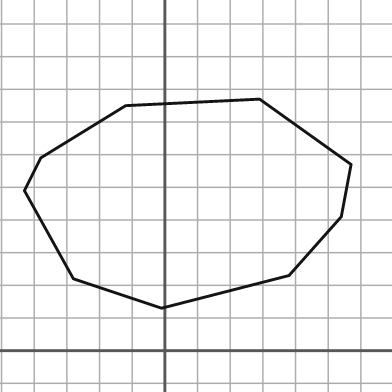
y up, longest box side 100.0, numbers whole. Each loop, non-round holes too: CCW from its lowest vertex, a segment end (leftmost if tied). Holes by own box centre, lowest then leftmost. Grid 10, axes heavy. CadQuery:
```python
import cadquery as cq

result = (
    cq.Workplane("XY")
    .moveTo(-1.0, 13.0)
    .lineTo(38.0, 23.0)
    .lineTo(54.0, 41.0)
    .lineTo(57.0, 57.0)
    .lineTo(29.0, 77.0)
    .lineTo(-12.0, 75.0)
    .lineTo(-38.0, 59.0)
    .lineTo(-43.0, 49.0)
    .lineTo(-28.0, 22.0)
    .close()
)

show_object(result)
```